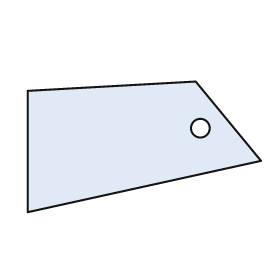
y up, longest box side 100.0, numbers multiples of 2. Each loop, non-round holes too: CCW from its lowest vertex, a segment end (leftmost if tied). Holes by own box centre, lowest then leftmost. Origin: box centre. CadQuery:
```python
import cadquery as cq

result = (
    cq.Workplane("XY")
    .moveTo(-50.0, -28.0)
    .lineTo(50.0, -6.0)
    .lineTo(22.0, 28.0)
    .lineTo(-50.0, 24.0)
    .close()
    .moveTo(24.0, 8.0)
    .circle(4.0)
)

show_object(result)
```